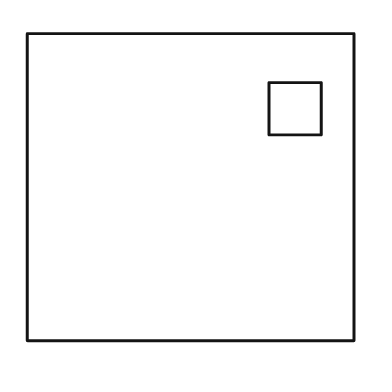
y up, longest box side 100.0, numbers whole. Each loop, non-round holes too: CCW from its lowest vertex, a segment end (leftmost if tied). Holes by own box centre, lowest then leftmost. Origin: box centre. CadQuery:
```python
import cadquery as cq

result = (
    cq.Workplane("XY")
    .moveTo(-50.0, -47.0)
    .lineTo(50.0, -47.0)
    .lineTo(50.0, 47.0)
    .lineTo(-50.0, 47.0)
    .close()
    .moveTo(24.0, 16.0)
    .lineTo(40.0, 16.0)
    .lineTo(40.0, 32.0)
    .lineTo(24.0, 32.0)
    .close()
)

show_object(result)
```